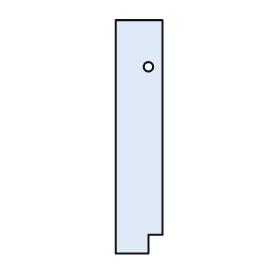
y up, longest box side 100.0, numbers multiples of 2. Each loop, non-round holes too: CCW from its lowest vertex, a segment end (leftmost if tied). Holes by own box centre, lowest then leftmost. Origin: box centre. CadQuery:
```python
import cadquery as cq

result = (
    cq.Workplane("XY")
    .moveTo(-10.0, -50.0)
    .lineTo(4.0, -50.0)
    .lineTo(4.0, -42.0)
    .lineTo(10.0, -42.0)
    .lineTo(10.0, 50.0)
    .lineTo(-10.0, 50.0)
    .close()
    .moveTo(4.0, 30.0)
    .circle(2.0)
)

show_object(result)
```